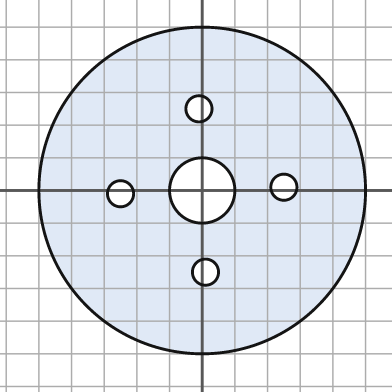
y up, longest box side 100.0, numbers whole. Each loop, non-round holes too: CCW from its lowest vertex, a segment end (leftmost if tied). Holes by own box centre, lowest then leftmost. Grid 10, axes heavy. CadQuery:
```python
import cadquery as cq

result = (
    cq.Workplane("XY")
    .moveTo(0.0, 0.0)
    .circle(50.0)
    .moveTo(1.0, -25.0)
    .circle(4.0)
    .moveTo(-25.0, -1.0)
    .circle(4.0)
    .moveTo(0.0, 0.0)
    .circle(10.0)
    .moveTo(25.0, 1.0)
    .circle(4.0)
    .moveTo(-1.0, 25.0)
    .circle(4.0)
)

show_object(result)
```